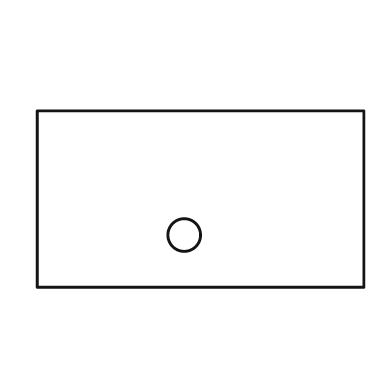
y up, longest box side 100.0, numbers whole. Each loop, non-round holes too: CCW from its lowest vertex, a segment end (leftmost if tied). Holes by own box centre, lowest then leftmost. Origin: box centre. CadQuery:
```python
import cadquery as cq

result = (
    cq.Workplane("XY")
    .moveTo(-50.0, -27.0)
    .lineTo(50.0, -27.0)
    .lineTo(50.0, 27.0)
    .lineTo(-50.0, 27.0)
    .close()
    .moveTo(-5.0, -11.0)
    .circle(5.0)
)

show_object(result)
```